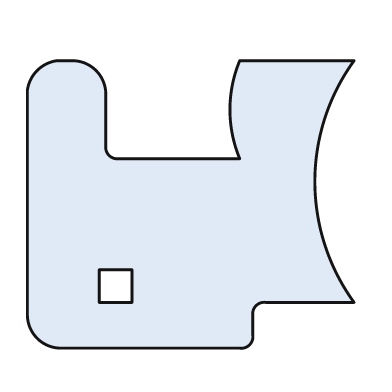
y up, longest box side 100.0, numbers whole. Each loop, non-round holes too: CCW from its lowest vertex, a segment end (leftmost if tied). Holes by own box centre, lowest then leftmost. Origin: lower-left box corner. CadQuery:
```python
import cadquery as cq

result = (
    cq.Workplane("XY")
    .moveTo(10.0, 0.0)
    .lineTo(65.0, 0.0)
    .threePointArc((68.0, 1.0), (69.0, 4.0))
    .lineTo(69.0, 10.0)
    .threePointArc((70.0, 13.0), (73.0, 14.0))
    .lineTo(100.0, 14.0)
    .threePointArc((88.0, 51.0), (100.0, 88.0))
    .lineTo(65.0, 88.0)
    .threePointArc((62.0, 73.0), (65.0, 58.0))
    .lineTo(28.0, 58.0)
    .threePointArc((25.0, 59.0), (24.0, 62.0))
    .lineTo(24.0, 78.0)
    .threePointArc((21.0, 85.0), (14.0, 88.0))
    .lineTo(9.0, 88.0)
    .threePointArc((3.0, 85.0), (0.0, 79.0))
    .lineTo(0.0, 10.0)
    .threePointArc((3.0, 3.0), (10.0, 0.0))
    .close()
    .moveTo(22.0, 14.0)
    .lineTo(32.0, 14.0)
    .lineTo(32.0, 24.0)
    .lineTo(22.0, 24.0)
    .close()
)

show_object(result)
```